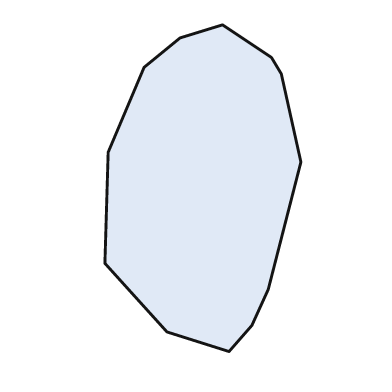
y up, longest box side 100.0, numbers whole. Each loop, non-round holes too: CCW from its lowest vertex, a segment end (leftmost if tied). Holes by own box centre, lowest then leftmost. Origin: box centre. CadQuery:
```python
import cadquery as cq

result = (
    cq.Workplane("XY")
    .moveTo(8.0, -50.0)
    .lineTo(15.0, -42.0)
    .lineTo(20.0, -31.0)
    .lineTo(30.0, 8.0)
    .lineTo(24.0, 35.0)
    .lineTo(21.0, 40.0)
    .lineTo(6.0, 50.0)
    .lineTo(-7.0, 46.0)
    .lineTo(-18.0, 37.0)
    .lineTo(-29.0, 11.0)
    .lineTo(-30.0, -23.0)
    .lineTo(-11.0, -44.0)
    .close()
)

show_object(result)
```